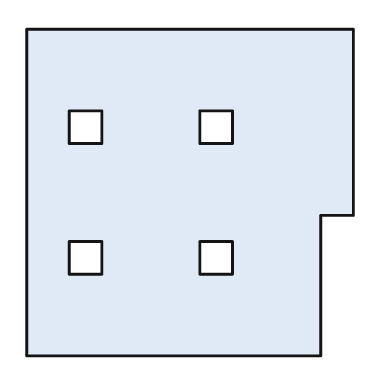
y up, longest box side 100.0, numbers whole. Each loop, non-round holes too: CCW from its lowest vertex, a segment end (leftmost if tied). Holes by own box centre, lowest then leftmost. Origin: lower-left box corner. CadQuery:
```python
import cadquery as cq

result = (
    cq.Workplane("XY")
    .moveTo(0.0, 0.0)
    .lineTo(90.0, 0.0)
    .lineTo(90.0, 43.0)
    .lineTo(100.0, 43.0)
    .lineTo(100.0, 100.0)
    .lineTo(0.0, 100.0)
    .close()
    .moveTo(13.0, 25.0)
    .lineTo(23.0, 25.0)
    .lineTo(23.0, 35.0)
    .lineTo(13.0, 35.0)
    .close()
    .moveTo(53.0, 25.0)
    .lineTo(63.0, 25.0)
    .lineTo(63.0, 35.0)
    .lineTo(53.0, 35.0)
    .close()
    .moveTo(13.0, 65.0)
    .lineTo(23.0, 65.0)
    .lineTo(23.0, 75.0)
    .lineTo(13.0, 75.0)
    .close()
    .moveTo(53.0, 65.0)
    .lineTo(63.0, 65.0)
    .lineTo(63.0, 75.0)
    .lineTo(53.0, 75.0)
    .close()
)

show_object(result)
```